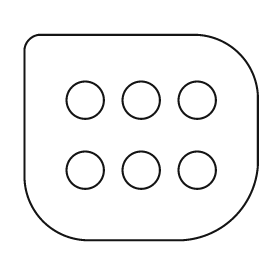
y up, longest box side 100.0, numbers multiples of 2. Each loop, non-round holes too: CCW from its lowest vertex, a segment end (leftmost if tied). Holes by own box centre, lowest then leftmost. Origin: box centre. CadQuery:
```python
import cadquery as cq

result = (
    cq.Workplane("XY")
    .moveTo(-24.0, -44.0)
    .lineTo(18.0, -44.0)
    .threePointArc((40.0, -34.0), (50.0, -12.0))
    .lineTo(50.0, 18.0)
    .threePointArc((42.0, 36.0), (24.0, 44.0))
    .lineTo(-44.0, 44.0)
    .threePointArc((-48.0, 42.0), (-50.0, 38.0))
    .lineTo(-50.0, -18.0)
    .threePointArc((-42.0, -36.0), (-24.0, -44.0))
    .close()
    .moveTo(-24.0, -14.0)
    .circle(8.0)
    .moveTo(0.0, -14.0)
    .circle(8.0)
    .moveTo(24.0, -14.0)
    .circle(8.0)
    .moveTo(-24.0, 16.0)
    .circle(8.0)
    .moveTo(0.0, 16.0)
    .circle(8.0)
    .moveTo(24.0, 16.0)
    .circle(8.0)
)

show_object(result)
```